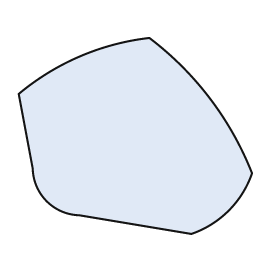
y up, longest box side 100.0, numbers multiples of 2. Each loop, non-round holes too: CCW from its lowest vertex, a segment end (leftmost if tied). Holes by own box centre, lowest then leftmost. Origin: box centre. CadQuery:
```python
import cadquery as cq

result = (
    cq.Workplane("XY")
    .moveTo(24.0, -42.0)
    .threePointArc((40.0, -32.0), (50.0, -16.0))
    .threePointArc((32.0, 16.0), (6.0, 42.0))
    .threePointArc((-24.0, 34.0), (-50.0, 18.0))
    .lineTo(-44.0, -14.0)
    .threePointArc((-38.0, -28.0), (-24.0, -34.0))
    .close()
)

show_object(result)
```